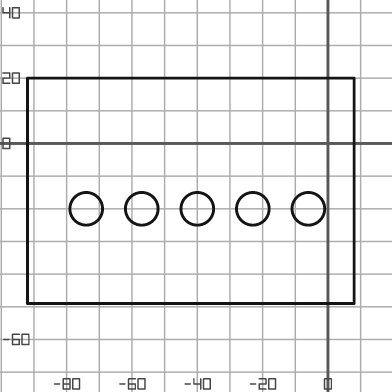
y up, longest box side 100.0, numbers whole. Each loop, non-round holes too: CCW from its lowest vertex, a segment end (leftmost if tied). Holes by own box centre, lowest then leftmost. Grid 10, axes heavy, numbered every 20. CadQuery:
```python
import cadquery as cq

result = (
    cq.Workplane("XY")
    .moveTo(-92.0, -49.0)
    .lineTo(8.0, -49.0)
    .lineTo(8.0, 20.0)
    .lineTo(-92.0, 20.0)
    .close()
    .moveTo(-74.0, -20.0)
    .circle(5.0)
    .moveTo(-57.0, -20.0)
    .circle(5.0)
    .moveTo(-40.0, -20.0)
    .circle(5.0)
    .moveTo(-23.0, -20.0)
    .circle(5.0)
    .moveTo(-6.0, -20.0)
    .circle(5.0)
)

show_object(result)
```